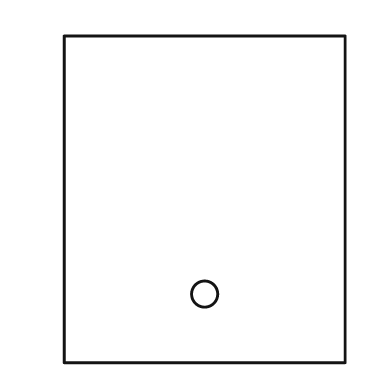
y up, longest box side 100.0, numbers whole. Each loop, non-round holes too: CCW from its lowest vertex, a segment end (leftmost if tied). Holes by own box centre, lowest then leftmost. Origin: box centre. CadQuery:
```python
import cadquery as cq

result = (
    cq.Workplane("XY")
    .moveTo(-43.0, -50.0)
    .lineTo(43.0, -50.0)
    .lineTo(43.0, 50.0)
    .lineTo(-43.0, 50.0)
    .close()
    .moveTo(0.0, -29.0)
    .circle(4.0)
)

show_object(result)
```